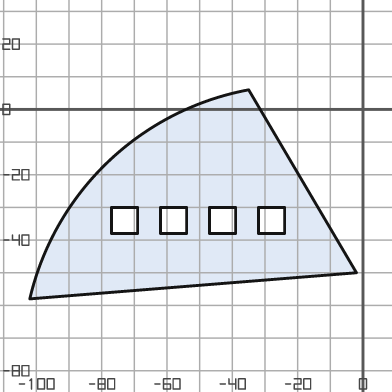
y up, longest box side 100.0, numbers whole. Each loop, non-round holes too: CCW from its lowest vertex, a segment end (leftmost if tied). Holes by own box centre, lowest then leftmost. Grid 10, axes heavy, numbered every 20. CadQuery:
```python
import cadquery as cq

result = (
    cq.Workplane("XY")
    .moveTo(-102.0, -58.0)
    .lineTo(-2.0, -50.0)
    .lineTo(-35.0, 6.0)
    .threePointArc((-78.0, -16.0), (-102.0, -58.0))
    .close()
    .moveTo(-77.0, -38.0)
    .lineTo(-69.0, -38.0)
    .lineTo(-69.0, -30.0)
    .lineTo(-77.0, -30.0)
    .close()
    .moveTo(-62.0, -38.0)
    .lineTo(-54.0, -38.0)
    .lineTo(-54.0, -30.0)
    .lineTo(-62.0, -30.0)
    .close()
    .moveTo(-47.0, -38.0)
    .lineTo(-39.0, -38.0)
    .lineTo(-39.0, -30.0)
    .lineTo(-47.0, -30.0)
    .close()
    .moveTo(-32.0, -38.0)
    .lineTo(-24.0, -38.0)
    .lineTo(-24.0, -30.0)
    .lineTo(-32.0, -30.0)
    .close()
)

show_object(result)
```